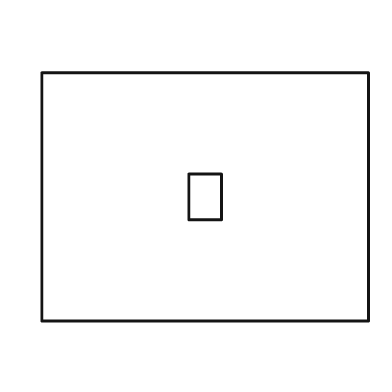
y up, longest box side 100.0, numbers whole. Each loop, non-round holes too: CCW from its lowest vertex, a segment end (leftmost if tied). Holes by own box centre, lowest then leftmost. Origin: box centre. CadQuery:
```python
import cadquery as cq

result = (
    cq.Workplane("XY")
    .moveTo(-50.0, -38.0)
    .lineTo(50.0, -38.0)
    .lineTo(50.0, 38.0)
    .lineTo(-50.0, 38.0)
    .close()
    .moveTo(-5.0, -7.0)
    .lineTo(5.0, -7.0)
    .lineTo(5.0, 7.0)
    .lineTo(-5.0, 7.0)
    .close()
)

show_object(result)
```